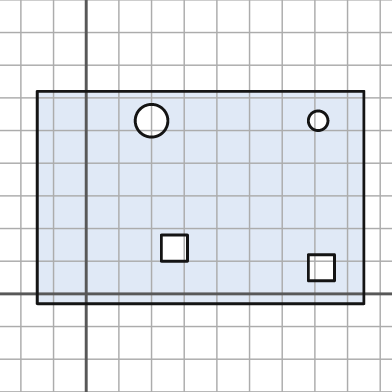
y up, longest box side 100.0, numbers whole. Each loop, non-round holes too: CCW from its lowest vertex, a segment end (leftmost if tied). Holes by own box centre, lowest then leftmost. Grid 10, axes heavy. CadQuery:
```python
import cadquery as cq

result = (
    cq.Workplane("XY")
    .moveTo(-15.0, -3.0)
    .lineTo(85.0, -3.0)
    .lineTo(85.0, 62.0)
    .lineTo(-15.0, 62.0)
    .close()
    .moveTo(68.0, 4.0)
    .lineTo(76.0, 4.0)
    .lineTo(76.0, 12.0)
    .lineTo(68.0, 12.0)
    .close()
    .moveTo(23.0, 10.0)
    .lineTo(31.0, 10.0)
    .lineTo(31.0, 18.0)
    .lineTo(23.0, 18.0)
    .close()
    .moveTo(20.0, 53.0)
    .circle(5.0)
    .moveTo(71.0, 53.0)
    .circle(3.0)
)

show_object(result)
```